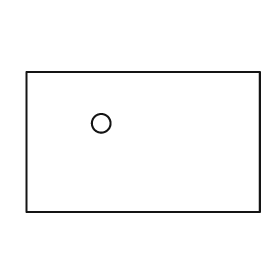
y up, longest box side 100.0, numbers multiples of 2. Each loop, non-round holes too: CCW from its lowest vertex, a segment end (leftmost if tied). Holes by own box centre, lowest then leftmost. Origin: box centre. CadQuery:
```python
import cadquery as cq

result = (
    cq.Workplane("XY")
    .moveTo(-50.0, -30.0)
    .lineTo(50.0, -30.0)
    .lineTo(50.0, 30.0)
    .lineTo(-50.0, 30.0)
    .close()
    .moveTo(-18.0, 8.0)
    .circle(4.0)
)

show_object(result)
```